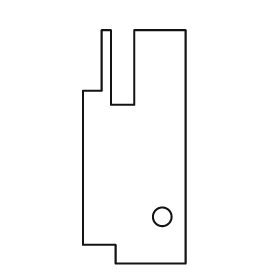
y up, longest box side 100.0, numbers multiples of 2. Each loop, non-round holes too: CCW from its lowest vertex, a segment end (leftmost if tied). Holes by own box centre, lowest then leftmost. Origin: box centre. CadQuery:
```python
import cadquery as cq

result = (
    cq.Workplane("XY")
    .moveTo(-8.0, -50.0)
    .lineTo(22.0, -50.0)
    .lineTo(22.0, 50.0)
    .lineTo(0.0, 50.0)
    .lineTo(0.0, 18.0)
    .lineTo(-10.0, 18.0)
    .lineTo(-10.0, 50.0)
    .lineTo(-14.0, 50.0)
    .lineTo(-14.0, 24.0)
    .lineTo(-22.0, 24.0)
    .lineTo(-22.0, -42.0)
    .lineTo(-8.0, -42.0)
    .close()
    .moveTo(12.0, -30.0)
    .circle(4.0)
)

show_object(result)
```